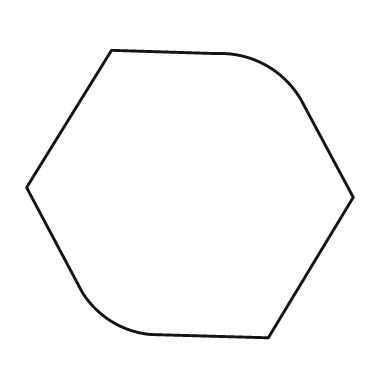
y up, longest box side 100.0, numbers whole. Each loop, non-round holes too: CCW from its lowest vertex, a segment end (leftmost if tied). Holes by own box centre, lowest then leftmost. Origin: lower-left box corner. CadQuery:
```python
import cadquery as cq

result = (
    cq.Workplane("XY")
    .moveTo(74.0, 0.0)
    .lineTo(100.0, 43.0)
    .lineTo(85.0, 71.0)
    .threePointArc((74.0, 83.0), (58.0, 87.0))
    .lineTo(26.0, 88.0)
    .lineTo(0.0, 46.0)
    .lineTo(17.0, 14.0)
    .threePointArc((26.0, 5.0), (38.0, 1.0))
    .close()
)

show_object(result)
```